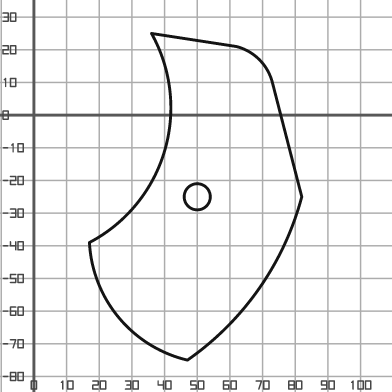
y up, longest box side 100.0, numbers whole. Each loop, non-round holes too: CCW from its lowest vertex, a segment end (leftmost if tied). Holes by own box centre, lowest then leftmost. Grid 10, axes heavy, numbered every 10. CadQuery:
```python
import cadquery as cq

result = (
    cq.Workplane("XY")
    .moveTo(47.0, -75.0)
    .threePointArc((69.0, -53.0), (82.0, -25.0))
    .lineTo(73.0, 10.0)
    .threePointArc((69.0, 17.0), (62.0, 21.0))
    .lineTo(36.0, 25.0)
    .threePointArc((40.0, -11.0), (17.0, -39.0))
    .threePointArc((26.0, -62.0), (47.0, -75.0))
    .close()
    .moveTo(50.0, -25.0)
    .circle(4.0)
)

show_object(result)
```